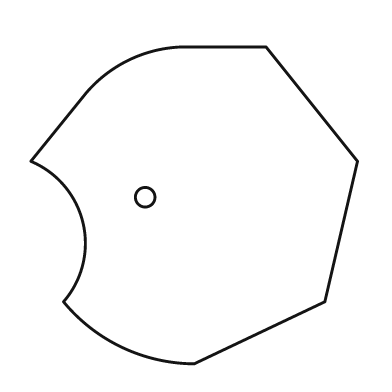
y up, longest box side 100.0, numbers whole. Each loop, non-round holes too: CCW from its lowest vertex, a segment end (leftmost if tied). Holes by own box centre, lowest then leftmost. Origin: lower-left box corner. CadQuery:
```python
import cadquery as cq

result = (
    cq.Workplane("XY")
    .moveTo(50.0, 0.0)
    .lineTo(90.0, 19.0)
    .lineTo(100.0, 62.0)
    .lineTo(72.0, 97.0)
    .lineTo(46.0, 97.0)
    .threePointArc((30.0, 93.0), (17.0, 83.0))
    .lineTo(0.0, 62.0)
    .threePointArc((16.0, 43.0), (10.0, 19.0))
    .threePointArc((28.0, 5.0), (50.0, 0.0))
    .close()
    .moveTo(35.0, 51.0)
    .circle(3.0)
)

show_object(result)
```